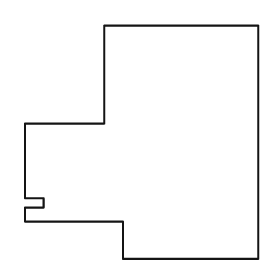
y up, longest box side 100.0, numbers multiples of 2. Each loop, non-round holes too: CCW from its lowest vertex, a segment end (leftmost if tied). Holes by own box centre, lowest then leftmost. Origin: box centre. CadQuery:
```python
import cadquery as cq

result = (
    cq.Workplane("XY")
    .moveTo(-8.0, -50.0)
    .lineTo(50.0, -50.0)
    .lineTo(50.0, 50.0)
    .lineTo(-16.0, 50.0)
    .lineTo(-16.0, 8.0)
    .lineTo(-50.0, 8.0)
    .lineTo(-50.0, -24.0)
    .lineTo(-42.0, -24.0)
    .lineTo(-42.0, -28.0)
    .lineTo(-50.0, -28.0)
    .lineTo(-50.0, -34.0)
    .lineTo(-8.0, -34.0)
    .close()
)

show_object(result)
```